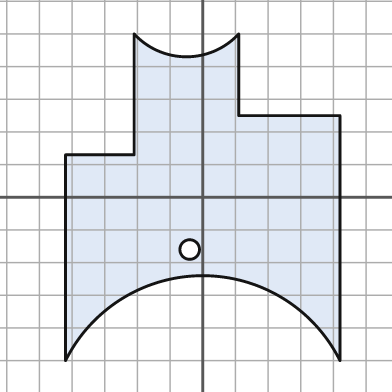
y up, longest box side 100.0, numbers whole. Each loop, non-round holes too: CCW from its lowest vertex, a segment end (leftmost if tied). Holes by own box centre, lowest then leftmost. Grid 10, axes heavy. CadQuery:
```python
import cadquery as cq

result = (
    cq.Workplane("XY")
    .moveTo(-42.0, -50.0)
    .threePointArc((0.0, -24.0), (42.0, -50.0))
    .lineTo(42.0, 25.0)
    .lineTo(11.0, 25.0)
    .lineTo(11.0, 50.0)
    .threePointArc((-5.0, 43.0), (-21.0, 50.0))
    .lineTo(-21.0, 13.0)
    .lineTo(-42.0, 13.0)
    .close()
    .moveTo(-4.0, -16.0)
    .circle(3.0)
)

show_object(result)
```